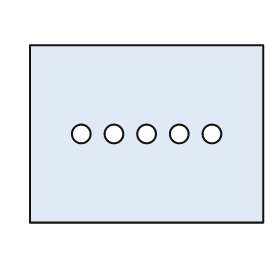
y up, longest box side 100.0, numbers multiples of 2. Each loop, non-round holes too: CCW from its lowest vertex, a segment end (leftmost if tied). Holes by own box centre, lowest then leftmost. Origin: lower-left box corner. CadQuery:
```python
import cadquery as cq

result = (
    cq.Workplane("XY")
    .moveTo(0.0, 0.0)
    .lineTo(100.0, 0.0)
    .lineTo(100.0, 76.0)
    .lineTo(0.0, 76.0)
    .close()
    .moveTo(22.0, 38.0)
    .circle(4.0)
    .moveTo(36.0, 38.0)
    .circle(4.0)
    .moveTo(50.0, 38.0)
    .circle(4.0)
    .moveTo(64.0, 38.0)
    .circle(4.0)
    .moveTo(78.0, 38.0)
    .circle(4.0)
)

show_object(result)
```